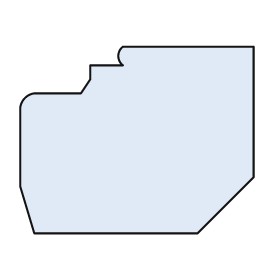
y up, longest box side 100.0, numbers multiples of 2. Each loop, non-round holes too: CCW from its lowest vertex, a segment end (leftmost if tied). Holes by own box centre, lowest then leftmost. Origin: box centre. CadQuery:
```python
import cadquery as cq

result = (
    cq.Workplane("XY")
    .moveTo(-44.0, -40.0)
    .lineTo(26.0, -40.0)
    .lineTo(50.0, -16.0)
    .lineTo(50.0, 40.0)
    .lineTo(-6.0, 40.0)
    .threePointArc((-8.0, 36.0), (-6.0, 32.0))
    .lineTo(-20.0, 32.0)
    .lineTo(-20.0, 26.0)
    .lineTo(-24.0, 20.0)
    .lineTo(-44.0, 20.0)
    .threePointArc((-48.0, 18.0), (-50.0, 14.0))
    .lineTo(-50.0, -20.0)
    .close()
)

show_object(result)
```